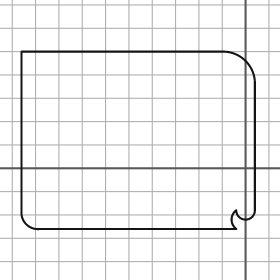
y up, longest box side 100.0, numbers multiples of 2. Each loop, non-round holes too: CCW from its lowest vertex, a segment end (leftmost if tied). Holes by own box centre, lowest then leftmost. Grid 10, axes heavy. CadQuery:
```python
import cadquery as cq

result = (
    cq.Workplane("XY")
    .moveTo(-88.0, -26.0)
    .lineTo(-4.0, -26.0)
    .threePointArc((-6.0, -22.0), (-4.0, -18.0))
    .threePointArc((0.0, -22.0), (4.0, -18.0))
    .lineTo(4.0, 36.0)
    .threePointArc((0.0, 46.0), (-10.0, 50.0))
    .lineTo(-96.0, 50.0)
    .lineTo(-96.0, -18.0)
    .threePointArc((-94.0, -24.0), (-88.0, -26.0))
    .close()
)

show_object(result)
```